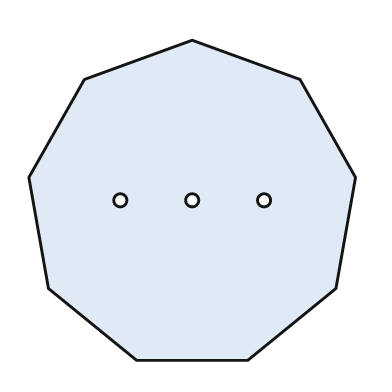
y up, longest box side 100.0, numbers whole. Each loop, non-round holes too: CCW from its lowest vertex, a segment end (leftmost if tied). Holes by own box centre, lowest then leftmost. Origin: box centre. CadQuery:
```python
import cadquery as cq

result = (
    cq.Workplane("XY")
    .moveTo(-17.0, -49.0)
    .lineTo(17.0, -49.0)
    .lineTo(44.0, -27.0)
    .lineTo(50.0, 7.0)
    .lineTo(33.0, 37.0)
    .lineTo(0.0, 49.0)
    .lineTo(-33.0, 37.0)
    .lineTo(-50.0, 7.0)
    .lineTo(-44.0, -27.0)
    .close()
    .moveTo(-22.0, 0.0)
    .circle(2.0)
    .moveTo(0.0, 0.0)
    .circle(2.0)
    .moveTo(22.0, 0.0)
    .circle(2.0)
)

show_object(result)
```